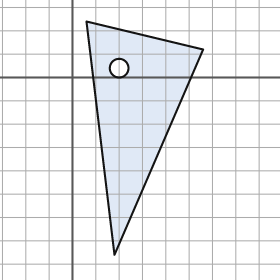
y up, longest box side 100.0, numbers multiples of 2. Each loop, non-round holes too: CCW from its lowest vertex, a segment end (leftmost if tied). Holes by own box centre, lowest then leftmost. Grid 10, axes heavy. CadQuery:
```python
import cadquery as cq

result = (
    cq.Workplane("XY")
    .moveTo(18.0, -76.0)
    .lineTo(56.0, 12.0)
    .lineTo(6.0, 24.0)
    .close()
    .moveTo(20.0, 4.0)
    .circle(4.0)
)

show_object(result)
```